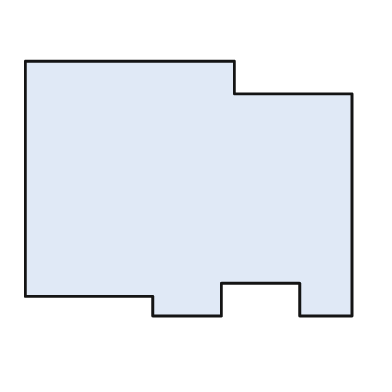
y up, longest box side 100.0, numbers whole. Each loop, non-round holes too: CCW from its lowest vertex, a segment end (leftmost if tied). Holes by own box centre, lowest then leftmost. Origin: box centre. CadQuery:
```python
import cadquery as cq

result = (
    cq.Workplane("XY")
    .moveTo(-11.0, -39.0)
    .lineTo(10.0, -39.0)
    .lineTo(10.0, -29.0)
    .lineTo(34.0, -29.0)
    .lineTo(34.0, -39.0)
    .lineTo(50.0, -39.0)
    .lineTo(50.0, 29.0)
    .lineTo(14.0, 29.0)
    .lineTo(14.0, 39.0)
    .lineTo(-50.0, 39.0)
    .lineTo(-50.0, -33.0)
    .lineTo(-11.0, -33.0)
    .close()
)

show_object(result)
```